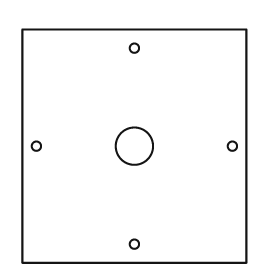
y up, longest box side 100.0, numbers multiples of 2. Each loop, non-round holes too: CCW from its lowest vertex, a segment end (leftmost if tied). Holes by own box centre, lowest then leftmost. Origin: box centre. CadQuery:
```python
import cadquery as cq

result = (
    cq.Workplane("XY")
    .moveTo(-48.0, -50.0)
    .lineTo(48.0, -50.0)
    .lineTo(48.0, 50.0)
    .lineTo(-48.0, 50.0)
    .close()
    .moveTo(0.0, -42.0)
    .circle(2.0)
    .moveTo(-42.0, 0.0)
    .circle(2.0)
    .moveTo(0.0, 0.0)
    .circle(8.0)
    .moveTo(42.0, 0.0)
    .circle(2.0)
    .moveTo(0.0, 42.0)
    .circle(2.0)
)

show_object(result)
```